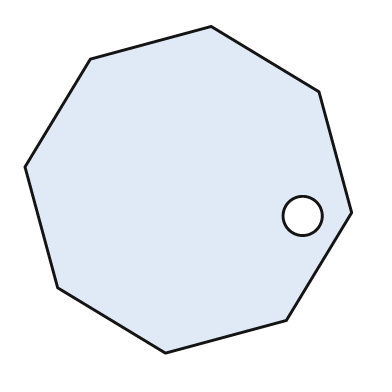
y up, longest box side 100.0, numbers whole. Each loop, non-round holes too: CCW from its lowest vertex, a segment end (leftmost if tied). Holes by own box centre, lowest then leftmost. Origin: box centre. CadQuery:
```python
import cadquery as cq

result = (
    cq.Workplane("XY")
    .moveTo(-7.0, -50.0)
    .lineTo(30.0, -40.0)
    .lineTo(50.0, -7.0)
    .lineTo(40.0, 30.0)
    .lineTo(7.0, 50.0)
    .lineTo(-30.0, 40.0)
    .lineTo(-50.0, 7.0)
    .lineTo(-40.0, -30.0)
    .close()
    .moveTo(35.0, -8.0)
    .circle(6.0)
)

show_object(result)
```